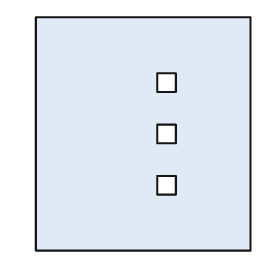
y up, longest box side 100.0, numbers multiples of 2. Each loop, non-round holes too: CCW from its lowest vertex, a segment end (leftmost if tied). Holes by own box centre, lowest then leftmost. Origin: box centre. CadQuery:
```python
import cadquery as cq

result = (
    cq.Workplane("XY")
    .moveTo(-46.0, -50.0)
    .lineTo(46.0, -50.0)
    .lineTo(46.0, 50.0)
    .lineTo(-46.0, 50.0)
    .close()
    .moveTo(6.0, -26.0)
    .lineTo(14.0, -26.0)
    .lineTo(14.0, -18.0)
    .lineTo(6.0, -18.0)
    .close()
    .moveTo(6.0, -4.0)
    .lineTo(14.0, -4.0)
    .lineTo(14.0, 4.0)
    .lineTo(6.0, 4.0)
    .close()
    .moveTo(6.0, 18.0)
    .lineTo(14.0, 18.0)
    .lineTo(14.0, 26.0)
    .lineTo(6.0, 26.0)
    .close()
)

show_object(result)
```